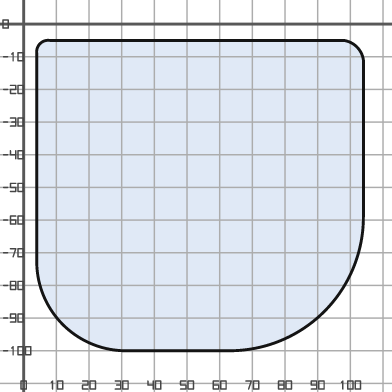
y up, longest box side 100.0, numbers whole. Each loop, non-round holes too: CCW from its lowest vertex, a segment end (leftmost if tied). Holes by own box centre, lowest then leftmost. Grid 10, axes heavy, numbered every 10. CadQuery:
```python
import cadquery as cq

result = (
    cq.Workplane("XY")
    .moveTo(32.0, -100.0)
    .lineTo(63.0, -100.0)
    .threePointArc((92.0, -88.0), (104.0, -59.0))
    .lineTo(104.0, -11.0)
    .threePointArc((102.0, -7.0), (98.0, -5.0))
    .lineTo(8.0, -5.0)
    .threePointArc((5.0, -6.0), (4.0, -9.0))
    .lineTo(4.0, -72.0)
    .threePointArc((12.0, -92.0), (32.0, -100.0))
    .close()
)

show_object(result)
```